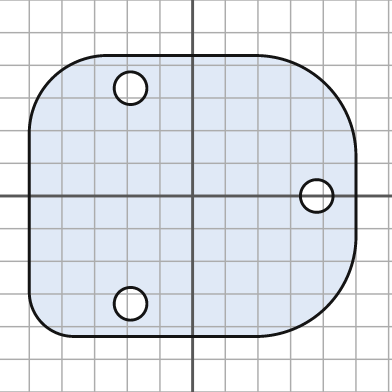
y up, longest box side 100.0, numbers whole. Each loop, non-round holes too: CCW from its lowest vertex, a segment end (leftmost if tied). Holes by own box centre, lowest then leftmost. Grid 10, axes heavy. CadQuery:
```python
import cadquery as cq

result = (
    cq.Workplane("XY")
    .moveTo(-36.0, -43.0)
    .lineTo(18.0, -43.0)
    .threePointArc((41.0, -34.0), (50.0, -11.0))
    .lineTo(50.0, 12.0)
    .threePointArc((41.0, 34.0), (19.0, 43.0))
    .lineTo(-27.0, 43.0)
    .threePointArc((-43.0, 36.0), (-50.0, 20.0))
    .lineTo(-50.0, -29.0)
    .threePointArc((-46.0, -39.0), (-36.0, -43.0))
    .close()
    .moveTo(-19.0, -33.0)
    .circle(5.0)
    .moveTo(38.0, 0.0)
    .circle(5.0)
    .moveTo(-19.0, 33.0)
    .circle(5.0)
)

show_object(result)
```